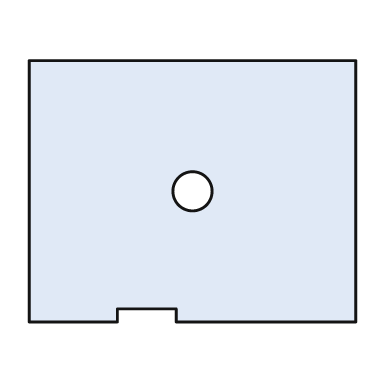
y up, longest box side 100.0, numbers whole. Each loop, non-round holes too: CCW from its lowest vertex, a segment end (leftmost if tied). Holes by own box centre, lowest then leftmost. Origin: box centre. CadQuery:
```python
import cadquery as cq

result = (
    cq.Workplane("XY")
    .moveTo(-50.0, -40.0)
    .lineTo(-23.0, -40.0)
    .lineTo(-23.0, -36.0)
    .lineTo(-5.0, -36.0)
    .lineTo(-5.0, -40.0)
    .lineTo(50.0, -40.0)
    .lineTo(50.0, 40.0)
    .lineTo(-50.0, 40.0)
    .close()
    .moveTo(0.0, 0.0)
    .circle(6.0)
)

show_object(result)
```